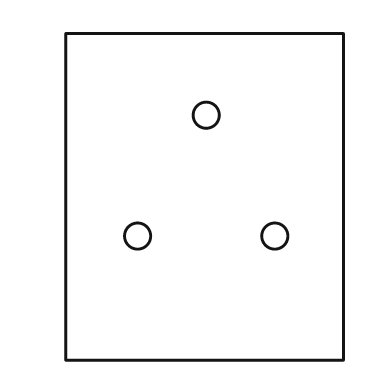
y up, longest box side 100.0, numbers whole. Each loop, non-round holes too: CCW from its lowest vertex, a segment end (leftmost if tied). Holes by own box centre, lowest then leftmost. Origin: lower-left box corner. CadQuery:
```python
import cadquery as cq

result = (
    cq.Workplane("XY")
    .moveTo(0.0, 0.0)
    .lineTo(85.0, 0.0)
    .lineTo(85.0, 100.0)
    .lineTo(0.0, 100.0)
    .close()
    .moveTo(22.0, 38.0)
    .circle(4.0)
    .moveTo(64.0, 38.0)
    .circle(4.0)
    .moveTo(43.0, 75.0)
    .circle(4.0)
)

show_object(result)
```